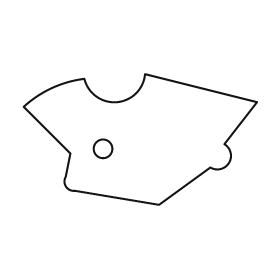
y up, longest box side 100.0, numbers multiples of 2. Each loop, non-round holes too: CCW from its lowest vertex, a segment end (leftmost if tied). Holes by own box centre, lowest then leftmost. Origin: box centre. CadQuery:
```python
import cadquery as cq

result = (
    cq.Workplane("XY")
    .moveTo(8.0, -28.0)
    .lineTo(30.0, -12.0)
    .threePointArc((38.0, -10.0), (36.0, -2.0))
    .lineTo(50.0, 16.0)
    .lineTo(2.0, 28.0)
    .threePointArc((-10.0, 16.0), (-24.0, 26.0))
    .threePointArc((-38.0, 22.0), (-50.0, 14.0))
    .lineTo(-30.0, -6.0)
    .lineTo(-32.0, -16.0)
    .threePointArc((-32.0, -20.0), (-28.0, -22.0))
    .close()
    .moveTo(-16.0, -4.0)
    .circle(4.0)
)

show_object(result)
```